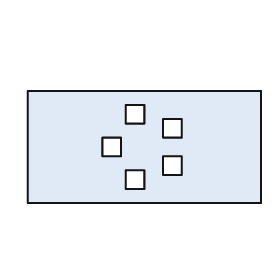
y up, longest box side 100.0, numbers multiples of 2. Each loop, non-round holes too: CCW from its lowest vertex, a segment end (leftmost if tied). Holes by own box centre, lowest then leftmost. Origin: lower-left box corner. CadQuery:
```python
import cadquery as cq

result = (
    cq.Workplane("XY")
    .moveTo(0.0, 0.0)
    .lineTo(100.0, 0.0)
    .lineTo(100.0, 48.0)
    .lineTo(0.0, 48.0)
    .close()
    .moveTo(42.0, 6.0)
    .lineTo(50.0, 6.0)
    .lineTo(50.0, 14.0)
    .lineTo(42.0, 14.0)
    .close()
    .moveTo(58.0, 12.0)
    .lineTo(66.0, 12.0)
    .lineTo(66.0, 20.0)
    .lineTo(58.0, 20.0)
    .close()
    .moveTo(32.0, 20.0)
    .lineTo(40.0, 20.0)
    .lineTo(40.0, 28.0)
    .lineTo(32.0, 28.0)
    .close()
    .moveTo(58.0, 28.0)
    .lineTo(66.0, 28.0)
    .lineTo(66.0, 36.0)
    .lineTo(58.0, 36.0)
    .close()
    .moveTo(42.0, 34.0)
    .lineTo(50.0, 34.0)
    .lineTo(50.0, 42.0)
    .lineTo(42.0, 42.0)
    .close()
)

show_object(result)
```